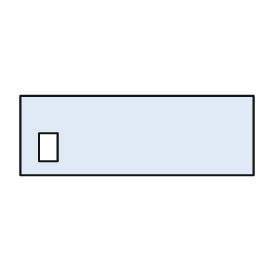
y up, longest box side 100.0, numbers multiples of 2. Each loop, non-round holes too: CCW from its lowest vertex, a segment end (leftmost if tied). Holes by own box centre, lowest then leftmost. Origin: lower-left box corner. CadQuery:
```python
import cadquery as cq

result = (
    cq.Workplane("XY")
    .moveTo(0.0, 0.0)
    .lineTo(100.0, 0.0)
    .lineTo(100.0, 34.0)
    .lineTo(0.0, 34.0)
    .close()
    .moveTo(8.0, 6.0)
    .lineTo(16.0, 6.0)
    .lineTo(16.0, 18.0)
    .lineTo(8.0, 18.0)
    .close()
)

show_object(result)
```